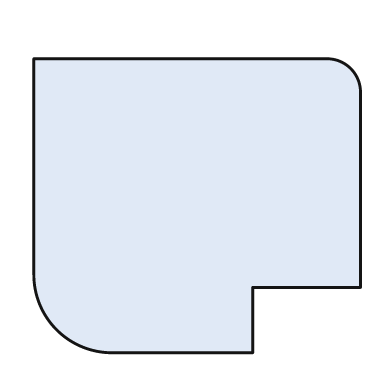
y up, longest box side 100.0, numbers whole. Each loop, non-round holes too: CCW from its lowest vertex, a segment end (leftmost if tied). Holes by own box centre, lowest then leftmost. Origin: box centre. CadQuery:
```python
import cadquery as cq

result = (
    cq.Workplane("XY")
    .moveTo(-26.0, -45.0)
    .lineTo(17.0, -45.0)
    .lineTo(17.0, -25.0)
    .lineTo(50.0, -25.0)
    .lineTo(50.0, 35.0)
    .threePointArc((47.0, 42.0), (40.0, 45.0))
    .lineTo(-50.0, 45.0)
    .lineTo(-50.0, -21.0)
    .threePointArc((-43.0, -38.0), (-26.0, -45.0))
    .close()
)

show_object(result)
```